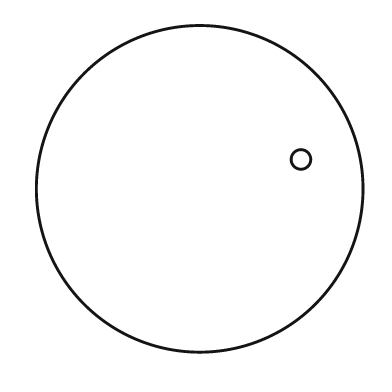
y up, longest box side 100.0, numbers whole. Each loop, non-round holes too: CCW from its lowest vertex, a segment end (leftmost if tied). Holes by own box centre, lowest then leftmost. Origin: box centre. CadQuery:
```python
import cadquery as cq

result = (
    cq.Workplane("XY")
    .moveTo(0.0, 0.0)
    .circle(50.0)
    .moveTo(31.0, 9.0)
    .circle(3.0)
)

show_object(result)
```